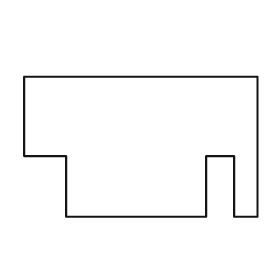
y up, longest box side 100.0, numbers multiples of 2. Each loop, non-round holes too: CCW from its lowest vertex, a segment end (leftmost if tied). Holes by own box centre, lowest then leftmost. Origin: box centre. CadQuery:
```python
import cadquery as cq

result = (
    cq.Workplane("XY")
    .moveTo(-32.0, -30.0)
    .lineTo(28.0, -30.0)
    .lineTo(28.0, -4.0)
    .lineTo(40.0, -4.0)
    .lineTo(40.0, -30.0)
    .lineTo(50.0, -30.0)
    .lineTo(50.0, 30.0)
    .lineTo(-50.0, 30.0)
    .lineTo(-50.0, -4.0)
    .lineTo(-32.0, -4.0)
    .close()
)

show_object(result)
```